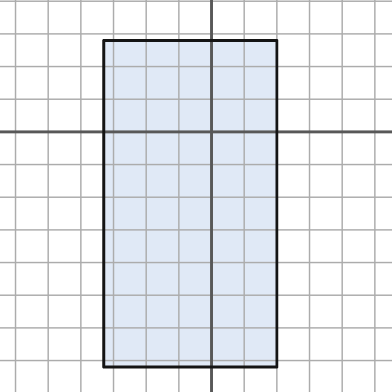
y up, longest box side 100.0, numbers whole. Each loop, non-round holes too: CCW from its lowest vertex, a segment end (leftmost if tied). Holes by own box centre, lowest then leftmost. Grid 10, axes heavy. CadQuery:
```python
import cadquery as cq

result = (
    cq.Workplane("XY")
    .moveTo(-33.0, -72.0)
    .lineTo(20.0, -72.0)
    .lineTo(20.0, 28.0)
    .lineTo(-33.0, 28.0)
    .close()
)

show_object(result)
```